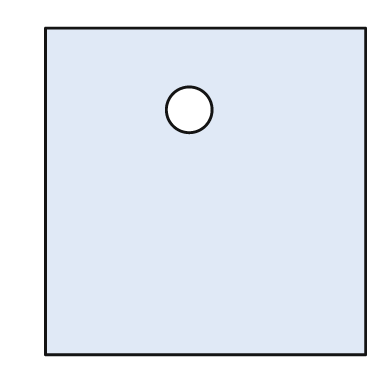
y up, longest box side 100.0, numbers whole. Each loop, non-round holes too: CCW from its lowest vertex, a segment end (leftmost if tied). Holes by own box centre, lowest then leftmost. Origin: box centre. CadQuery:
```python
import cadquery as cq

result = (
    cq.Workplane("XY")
    .moveTo(-49.0, -50.0)
    .lineTo(49.0, -50.0)
    .lineTo(49.0, 50.0)
    .lineTo(-49.0, 50.0)
    .close()
    .moveTo(-5.0, 25.0)
    .circle(7.0)
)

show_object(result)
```